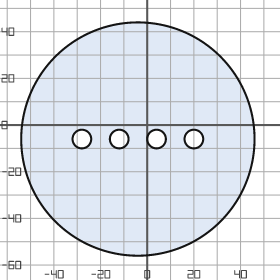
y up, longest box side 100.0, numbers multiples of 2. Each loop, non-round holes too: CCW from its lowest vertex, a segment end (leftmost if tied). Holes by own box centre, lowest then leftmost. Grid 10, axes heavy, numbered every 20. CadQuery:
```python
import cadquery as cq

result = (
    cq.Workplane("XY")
    .moveTo(-4.0, -6.0)
    .circle(50.0)
    .moveTo(-28.0, -6.0)
    .circle(4.0)
    .moveTo(-12.0, -6.0)
    .circle(4.0)
    .moveTo(4.0, -6.0)
    .circle(4.0)
    .moveTo(20.0, -6.0)
    .circle(4.0)
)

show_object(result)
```